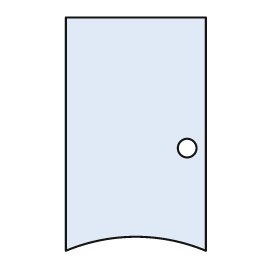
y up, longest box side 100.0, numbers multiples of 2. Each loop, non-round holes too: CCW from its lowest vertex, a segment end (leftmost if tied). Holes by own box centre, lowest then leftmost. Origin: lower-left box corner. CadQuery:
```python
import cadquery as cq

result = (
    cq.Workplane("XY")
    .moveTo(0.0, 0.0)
    .threePointArc((30.0, 6.0), (60.0, 0.0))
    .lineTo(60.0, 100.0)
    .lineTo(0.0, 100.0)
    .close()
    .moveTo(52.0, 44.0)
    .circle(4.0)
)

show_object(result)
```